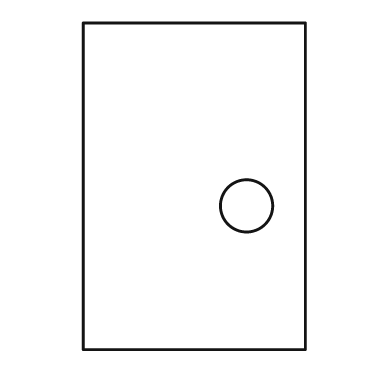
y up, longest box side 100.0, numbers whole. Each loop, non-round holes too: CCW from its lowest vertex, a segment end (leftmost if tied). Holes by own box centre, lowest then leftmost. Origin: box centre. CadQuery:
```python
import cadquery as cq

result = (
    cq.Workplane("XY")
    .moveTo(-34.0, -50.0)
    .lineTo(34.0, -50.0)
    .lineTo(34.0, 50.0)
    .lineTo(-34.0, 50.0)
    .close()
    .moveTo(16.0, -6.0)
    .circle(8.0)
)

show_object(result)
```